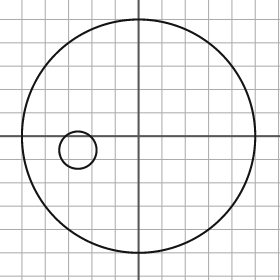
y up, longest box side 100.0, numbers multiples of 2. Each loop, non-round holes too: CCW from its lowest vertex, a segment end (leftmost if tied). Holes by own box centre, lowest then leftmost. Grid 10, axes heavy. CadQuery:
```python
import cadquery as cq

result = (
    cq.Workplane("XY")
    .moveTo(0.0, 0.0)
    .circle(50.0)
    .moveTo(-26.0, -6.0)
    .circle(8.0)
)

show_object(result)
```